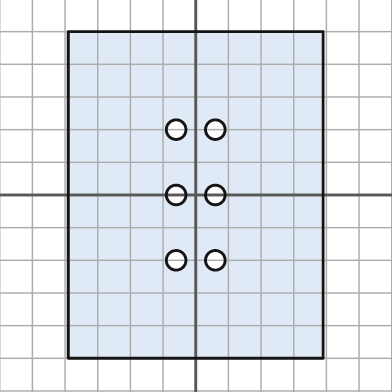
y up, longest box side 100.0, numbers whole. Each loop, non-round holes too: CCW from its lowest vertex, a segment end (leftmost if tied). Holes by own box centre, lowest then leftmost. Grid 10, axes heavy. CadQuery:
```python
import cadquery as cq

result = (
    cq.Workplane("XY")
    .moveTo(-39.0, -50.0)
    .lineTo(39.0, -50.0)
    .lineTo(39.0, 50.0)
    .lineTo(-39.0, 50.0)
    .close()
    .moveTo(-6.0, -20.0)
    .circle(3.0)
    .moveTo(6.0, -20.0)
    .circle(3.0)
    .moveTo(-6.0, 0.0)
    .circle(3.0)
    .moveTo(6.0, 0.0)
    .circle(3.0)
    .moveTo(-6.0, 20.0)
    .circle(3.0)
    .moveTo(6.0, 20.0)
    .circle(3.0)
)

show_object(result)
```